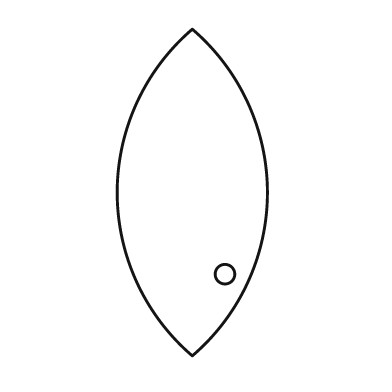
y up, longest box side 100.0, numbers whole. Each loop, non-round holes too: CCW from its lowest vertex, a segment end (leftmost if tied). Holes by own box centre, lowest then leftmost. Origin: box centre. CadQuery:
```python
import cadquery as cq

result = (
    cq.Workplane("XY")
    .moveTo(0.0, -50.0)
    .threePointArc((23.0, 0.0), (0.0, 50.0))
    .threePointArc((-23.0, 0.0), (0.0, -50.0))
    .close()
    .moveTo(10.0, -25.0)
    .circle(3.0)
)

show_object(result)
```